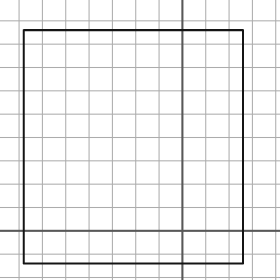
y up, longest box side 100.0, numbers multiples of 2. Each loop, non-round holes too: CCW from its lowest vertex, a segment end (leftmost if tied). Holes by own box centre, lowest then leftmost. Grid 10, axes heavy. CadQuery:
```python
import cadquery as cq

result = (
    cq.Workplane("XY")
    .moveTo(-68.0, -14.0)
    .lineTo(26.0, -14.0)
    .lineTo(26.0, 86.0)
    .lineTo(-68.0, 86.0)
    .close()
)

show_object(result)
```